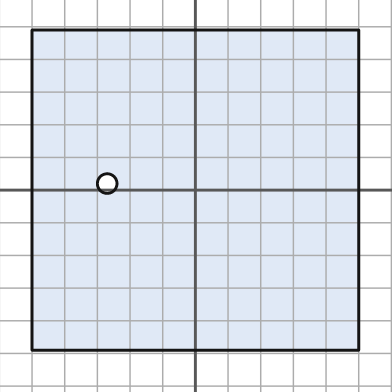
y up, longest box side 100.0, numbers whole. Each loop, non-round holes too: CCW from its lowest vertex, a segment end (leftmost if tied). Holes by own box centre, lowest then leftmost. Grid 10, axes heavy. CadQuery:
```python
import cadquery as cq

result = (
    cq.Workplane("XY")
    .moveTo(-50.0, -49.0)
    .lineTo(50.0, -49.0)
    .lineTo(50.0, 49.0)
    .lineTo(-50.0, 49.0)
    .close()
    .moveTo(-27.0, 2.0)
    .circle(3.0)
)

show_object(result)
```